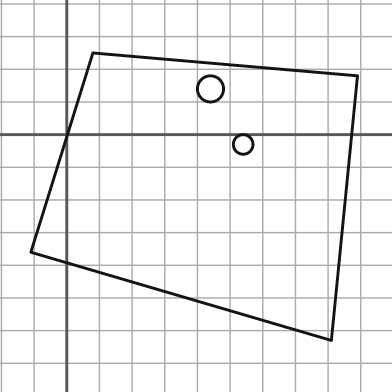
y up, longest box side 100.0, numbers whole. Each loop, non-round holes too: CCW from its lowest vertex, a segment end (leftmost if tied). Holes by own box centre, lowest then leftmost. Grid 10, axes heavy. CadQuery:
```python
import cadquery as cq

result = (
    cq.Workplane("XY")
    .moveTo(81.0, -63.0)
    .lineTo(89.0, 18.0)
    .lineTo(8.0, 25.0)
    .lineTo(-11.0, -36.0)
    .close()
    .moveTo(54.0, -3.0)
    .circle(3.0)
    .moveTo(44.0, 14.0)
    .circle(4.0)
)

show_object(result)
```